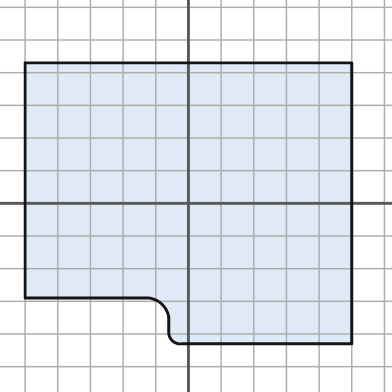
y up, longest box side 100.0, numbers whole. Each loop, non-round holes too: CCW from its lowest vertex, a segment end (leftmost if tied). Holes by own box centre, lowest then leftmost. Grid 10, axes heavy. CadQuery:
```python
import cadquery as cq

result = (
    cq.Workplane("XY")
    .moveTo(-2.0, -43.0)
    .lineTo(50.0, -43.0)
    .lineTo(50.0, 43.0)
    .lineTo(-50.0, 43.0)
    .lineTo(-50.0, -29.0)
    .lineTo(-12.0, -29.0)
    .threePointArc((-8.0, -31.0), (-6.0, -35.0))
    .lineTo(-6.0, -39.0)
    .threePointArc((-5.0, -42.0), (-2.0, -43.0))
    .close()
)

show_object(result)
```